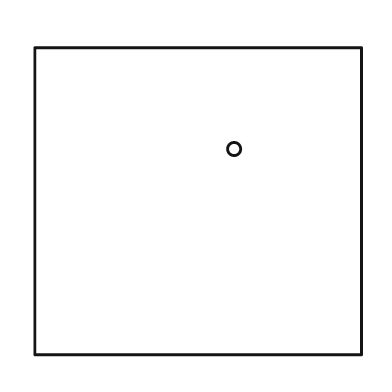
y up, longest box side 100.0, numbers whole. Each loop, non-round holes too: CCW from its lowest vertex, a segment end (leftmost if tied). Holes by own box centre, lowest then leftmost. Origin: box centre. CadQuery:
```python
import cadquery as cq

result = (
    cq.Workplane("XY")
    .moveTo(-50.0, -47.0)
    .lineTo(50.0, -47.0)
    .lineTo(50.0, 47.0)
    .lineTo(-50.0, 47.0)
    .close()
    .moveTo(11.0, 16.0)
    .circle(2.0)
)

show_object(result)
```